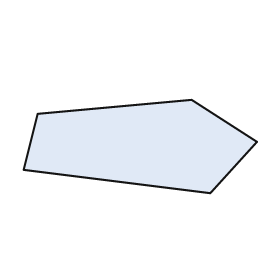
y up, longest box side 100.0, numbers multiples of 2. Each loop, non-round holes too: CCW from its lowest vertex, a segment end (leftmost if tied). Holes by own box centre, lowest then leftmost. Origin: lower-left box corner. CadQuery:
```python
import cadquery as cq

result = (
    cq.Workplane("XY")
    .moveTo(80.0, 0.0)
    .lineTo(100.0, 22.0)
    .lineTo(72.0, 40.0)
    .lineTo(6.0, 34.0)
    .lineTo(0.0, 10.0)
    .close()
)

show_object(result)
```